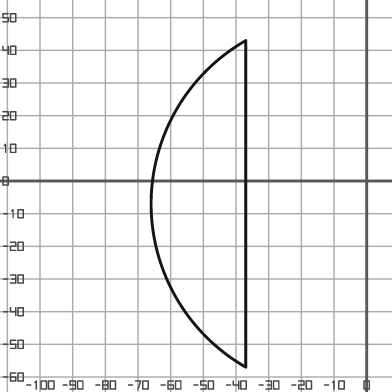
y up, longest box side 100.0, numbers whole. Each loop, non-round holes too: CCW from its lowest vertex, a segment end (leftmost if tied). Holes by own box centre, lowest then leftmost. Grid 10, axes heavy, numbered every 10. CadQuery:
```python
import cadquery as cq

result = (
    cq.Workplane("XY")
    .moveTo(-37.0, -57.0)
    .lineTo(-37.0, 43.0)
    .threePointArc((-66.0, -7.0), (-37.0, -57.0))
    .close()
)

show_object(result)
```